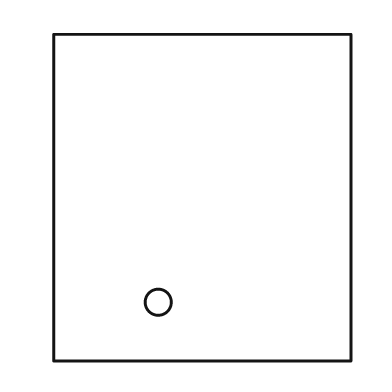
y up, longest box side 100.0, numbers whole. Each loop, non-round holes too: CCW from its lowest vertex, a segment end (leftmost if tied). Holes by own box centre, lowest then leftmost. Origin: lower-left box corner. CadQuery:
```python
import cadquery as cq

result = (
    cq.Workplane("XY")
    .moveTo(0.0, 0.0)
    .lineTo(91.0, 0.0)
    .lineTo(91.0, 100.0)
    .lineTo(0.0, 100.0)
    .close()
    .moveTo(32.0, 18.0)
    .circle(4.0)
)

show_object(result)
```